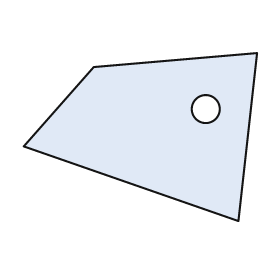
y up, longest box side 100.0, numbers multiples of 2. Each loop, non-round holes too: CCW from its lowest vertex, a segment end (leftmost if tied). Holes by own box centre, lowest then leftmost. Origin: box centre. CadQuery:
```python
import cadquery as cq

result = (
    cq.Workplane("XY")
    .moveTo(42.0, -36.0)
    .lineTo(50.0, 36.0)
    .lineTo(-20.0, 30.0)
    .lineTo(-50.0, -4.0)
    .close()
    .moveTo(28.0, 12.0)
    .circle(6.0)
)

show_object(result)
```